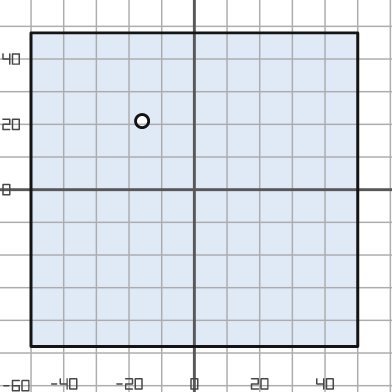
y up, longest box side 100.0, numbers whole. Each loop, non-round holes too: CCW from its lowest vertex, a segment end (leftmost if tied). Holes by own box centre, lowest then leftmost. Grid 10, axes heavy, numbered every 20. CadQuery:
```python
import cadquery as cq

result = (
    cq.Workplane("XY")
    .moveTo(-50.0, -48.0)
    .lineTo(50.0, -48.0)
    .lineTo(50.0, 48.0)
    .lineTo(-50.0, 48.0)
    .close()
    .moveTo(-16.0, 21.0)
    .circle(2.0)
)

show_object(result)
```